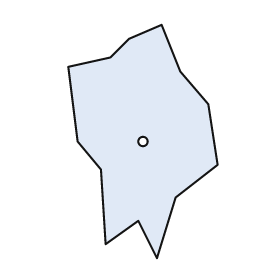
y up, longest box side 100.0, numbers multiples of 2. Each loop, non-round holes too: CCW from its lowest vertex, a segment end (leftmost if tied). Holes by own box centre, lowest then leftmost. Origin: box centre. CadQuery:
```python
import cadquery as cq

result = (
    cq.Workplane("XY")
    .moveTo(6.0, -50.0)
    .lineTo(14.0, -24.0)
    .lineTo(32.0, -10.0)
    .lineTo(28.0, 16.0)
    .lineTo(16.0, 30.0)
    .lineTo(8.0, 50.0)
    .lineTo(-6.0, 44.0)
    .lineTo(-14.0, 36.0)
    .lineTo(-32.0, 32.0)
    .lineTo(-28.0, 0.0)
    .lineTo(-18.0, -12.0)
    .lineTo(-16.0, -44.0)
    .lineTo(-2.0, -34.0)
    .close()
    .moveTo(0.0, 0.0)
    .circle(2.0)
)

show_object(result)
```